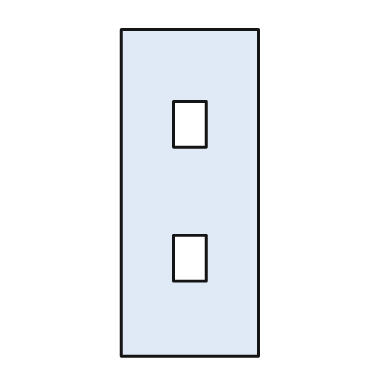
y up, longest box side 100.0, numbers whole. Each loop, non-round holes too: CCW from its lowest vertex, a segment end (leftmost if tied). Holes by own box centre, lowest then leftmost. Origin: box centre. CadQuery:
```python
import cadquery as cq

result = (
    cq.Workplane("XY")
    .moveTo(-21.0, -50.0)
    .lineTo(21.0, -50.0)
    .lineTo(21.0, 50.0)
    .lineTo(-21.0, 50.0)
    .close()
    .moveTo(-5.0, -27.0)
    .lineTo(5.0, -27.0)
    .lineTo(5.0, -13.0)
    .lineTo(-5.0, -13.0)
    .close()
    .moveTo(-5.0, 14.0)
    .lineTo(5.0, 14.0)
    .lineTo(5.0, 28.0)
    .lineTo(-5.0, 28.0)
    .close()
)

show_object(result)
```